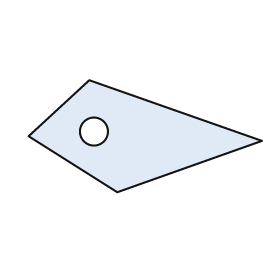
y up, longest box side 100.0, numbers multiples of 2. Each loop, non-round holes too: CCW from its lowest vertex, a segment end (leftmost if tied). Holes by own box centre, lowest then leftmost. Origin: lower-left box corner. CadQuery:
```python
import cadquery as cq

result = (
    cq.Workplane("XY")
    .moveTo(38.0, 0.0)
    .lineTo(100.0, 22.0)
    .lineTo(26.0, 48.0)
    .lineTo(0.0, 24.0)
    .close()
    .moveTo(28.0, 26.0)
    .circle(6.0)
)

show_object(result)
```